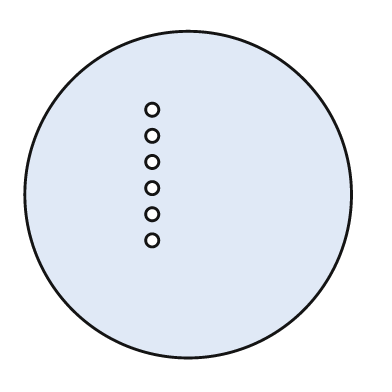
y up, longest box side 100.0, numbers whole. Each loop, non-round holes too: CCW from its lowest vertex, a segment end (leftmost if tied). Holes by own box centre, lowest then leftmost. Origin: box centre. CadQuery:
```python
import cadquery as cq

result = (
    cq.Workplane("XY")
    .moveTo(0.0, 0.0)
    .circle(50.0)
    .moveTo(-11.0, -14.0)
    .circle(2.0)
    .moveTo(-11.0, -6.0)
    .circle(2.0)
    .moveTo(-11.0, 2.0)
    .circle(2.0)
    .moveTo(-11.0, 10.0)
    .circle(2.0)
    .moveTo(-11.0, 18.0)
    .circle(2.0)
    .moveTo(-11.0, 26.0)
    .circle(2.0)
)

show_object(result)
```